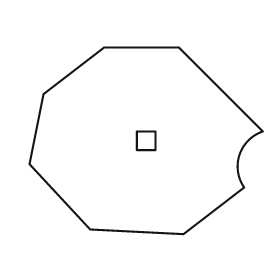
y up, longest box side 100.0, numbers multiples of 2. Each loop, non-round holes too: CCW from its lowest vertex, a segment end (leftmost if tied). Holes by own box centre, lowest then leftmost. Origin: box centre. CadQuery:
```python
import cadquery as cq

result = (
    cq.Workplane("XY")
    .moveTo(16.0, -40.0)
    .lineTo(42.0, -20.0)
    .threePointArc((40.0, -6.0), (50.0, 4.0))
    .lineTo(14.0, 40.0)
    .lineTo(-18.0, 40.0)
    .lineTo(-44.0, 20.0)
    .lineTo(-50.0, -10.0)
    .lineTo(-24.0, -38.0)
    .close()
    .moveTo(-4.0, -4.0)
    .lineTo(4.0, -4.0)
    .lineTo(4.0, 4.0)
    .lineTo(-4.0, 4.0)
    .close()
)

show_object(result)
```